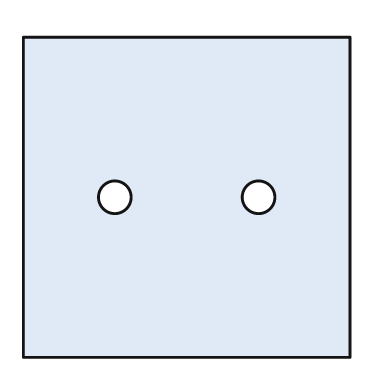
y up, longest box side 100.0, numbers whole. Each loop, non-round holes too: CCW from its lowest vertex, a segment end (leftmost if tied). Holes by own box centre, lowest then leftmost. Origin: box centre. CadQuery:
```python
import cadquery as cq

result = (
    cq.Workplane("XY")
    .moveTo(-50.0, -49.0)
    .lineTo(50.0, -49.0)
    .lineTo(50.0, 49.0)
    .lineTo(-50.0, 49.0)
    .close()
    .moveTo(-22.0, 0.0)
    .circle(5.0)
    .moveTo(22.0, 0.0)
    .circle(5.0)
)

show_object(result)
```